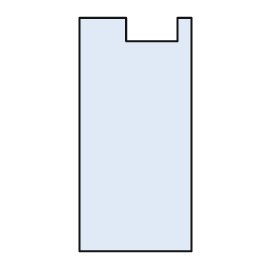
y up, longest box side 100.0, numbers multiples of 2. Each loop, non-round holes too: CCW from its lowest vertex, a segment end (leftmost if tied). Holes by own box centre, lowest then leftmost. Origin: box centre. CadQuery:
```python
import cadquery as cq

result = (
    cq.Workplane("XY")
    .moveTo(-24.0, -50.0)
    .lineTo(24.0, -50.0)
    .lineTo(24.0, 50.0)
    .lineTo(18.0, 50.0)
    .lineTo(18.0, 40.0)
    .lineTo(-4.0, 40.0)
    .lineTo(-4.0, 50.0)
    .lineTo(-24.0, 50.0)
    .close()
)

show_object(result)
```